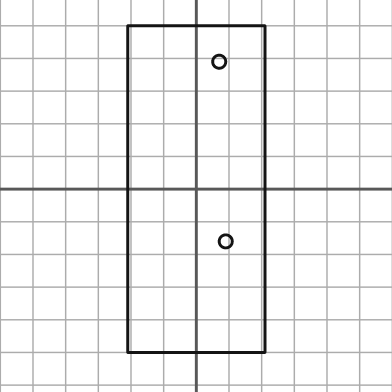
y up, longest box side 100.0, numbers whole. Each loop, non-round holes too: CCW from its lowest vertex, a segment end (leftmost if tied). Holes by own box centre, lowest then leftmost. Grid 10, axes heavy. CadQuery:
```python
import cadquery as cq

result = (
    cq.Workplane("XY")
    .moveTo(-21.0, -50.0)
    .lineTo(21.0, -50.0)
    .lineTo(21.0, 50.0)
    .lineTo(-21.0, 50.0)
    .close()
    .moveTo(9.0, -16.0)
    .circle(2.0)
    .moveTo(7.0, 39.0)
    .circle(2.0)
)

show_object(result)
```